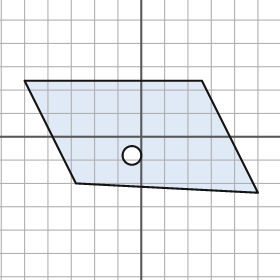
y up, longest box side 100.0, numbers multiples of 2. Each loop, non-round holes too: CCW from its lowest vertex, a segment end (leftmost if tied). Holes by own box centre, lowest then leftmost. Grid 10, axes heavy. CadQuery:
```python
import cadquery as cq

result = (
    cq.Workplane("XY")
    .moveTo(50.0, -24.0)
    .lineTo(26.0, 24.0)
    .lineTo(-50.0, 24.0)
    .lineTo(-28.0, -20.0)
    .close()
    .moveTo(-4.0, -8.0)
    .circle(4.0)
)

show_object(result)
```